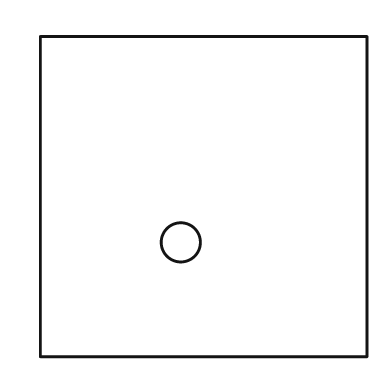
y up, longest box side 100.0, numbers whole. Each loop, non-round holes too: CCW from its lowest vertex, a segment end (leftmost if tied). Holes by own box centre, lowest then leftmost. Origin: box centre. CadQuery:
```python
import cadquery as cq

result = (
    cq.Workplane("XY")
    .moveTo(-50.0, -49.0)
    .lineTo(50.0, -49.0)
    .lineTo(50.0, 49.0)
    .lineTo(-50.0, 49.0)
    .close()
    .moveTo(-7.0, -14.0)
    .circle(6.0)
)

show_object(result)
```